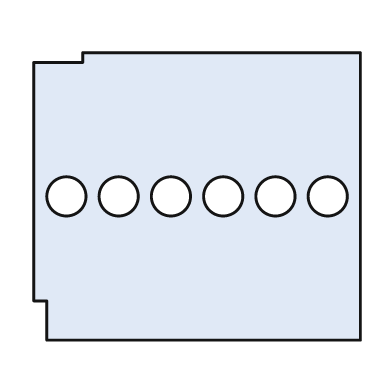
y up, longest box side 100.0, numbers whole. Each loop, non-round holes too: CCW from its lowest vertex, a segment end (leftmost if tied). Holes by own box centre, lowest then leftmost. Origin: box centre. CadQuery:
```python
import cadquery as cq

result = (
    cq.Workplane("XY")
    .moveTo(-46.0, -44.0)
    .lineTo(50.0, -44.0)
    .lineTo(50.0, 44.0)
    .lineTo(-35.0, 44.0)
    .lineTo(-35.0, 41.0)
    .lineTo(-50.0, 41.0)
    .lineTo(-50.0, -32.0)
    .lineTo(-46.0, -32.0)
    .close()
    .moveTo(-40.0, 0.0)
    .circle(6.0)
    .moveTo(-24.0, 0.0)
    .circle(6.0)
    .moveTo(-8.0, 0.0)
    .circle(6.0)
    .moveTo(8.0, 0.0)
    .circle(6.0)
    .moveTo(24.0, 0.0)
    .circle(6.0)
    .moveTo(40.0, 0.0)
    .circle(6.0)
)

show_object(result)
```